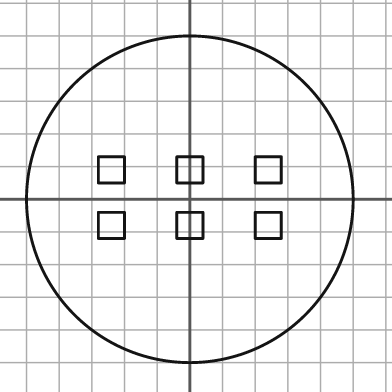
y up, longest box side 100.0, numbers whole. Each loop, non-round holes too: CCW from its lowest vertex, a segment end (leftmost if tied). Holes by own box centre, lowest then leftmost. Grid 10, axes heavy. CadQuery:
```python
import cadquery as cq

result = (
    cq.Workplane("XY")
    .moveTo(0.0, 0.0)
    .circle(50.0)
    .moveTo(-28.0, -12.0)
    .lineTo(-20.0, -12.0)
    .lineTo(-20.0, -4.0)
    .lineTo(-28.0, -4.0)
    .close()
    .moveTo(-4.0, -12.0)
    .lineTo(4.0, -12.0)
    .lineTo(4.0, -4.0)
    .lineTo(-4.0, -4.0)
    .close()
    .moveTo(20.0, -12.0)
    .lineTo(28.0, -12.0)
    .lineTo(28.0, -4.0)
    .lineTo(20.0, -4.0)
    .close()
    .moveTo(-28.0, 5.0)
    .lineTo(-20.0, 5.0)
    .lineTo(-20.0, 13.0)
    .lineTo(-28.0, 13.0)
    .close()
    .moveTo(-4.0, 5.0)
    .lineTo(4.0, 5.0)
    .lineTo(4.0, 13.0)
    .lineTo(-4.0, 13.0)
    .close()
    .moveTo(20.0, 5.0)
    .lineTo(28.0, 5.0)
    .lineTo(28.0, 13.0)
    .lineTo(20.0, 13.0)
    .close()
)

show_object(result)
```